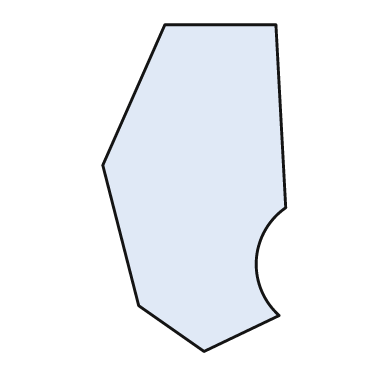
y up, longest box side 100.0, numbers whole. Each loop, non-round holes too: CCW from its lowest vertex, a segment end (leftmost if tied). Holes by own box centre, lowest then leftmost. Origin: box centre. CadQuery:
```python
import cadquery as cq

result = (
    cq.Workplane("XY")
    .moveTo(3.0, -50.0)
    .lineTo(26.0, -39.0)
    .threePointArc((19.0, -22.0), (28.0, -6.0))
    .lineTo(25.0, 50.0)
    .lineTo(-9.0, 50.0)
    .lineTo(-28.0, 7.0)
    .lineTo(-17.0, -36.0)
    .close()
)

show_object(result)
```